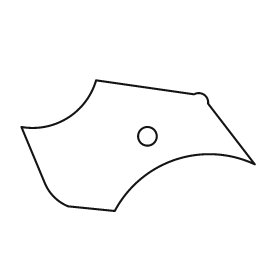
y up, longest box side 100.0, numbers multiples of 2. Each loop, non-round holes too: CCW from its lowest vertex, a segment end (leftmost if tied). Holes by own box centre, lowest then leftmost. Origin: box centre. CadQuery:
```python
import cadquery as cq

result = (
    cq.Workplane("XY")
    .moveTo(-10.0, -28.0)
    .threePointArc((16.0, -6.0), (50.0, -8.0))
    .lineTo(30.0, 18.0)
    .threePointArc((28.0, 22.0), (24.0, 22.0))
    .lineTo(-18.0, 28.0)
    .threePointArc((-30.0, 12.0), (-50.0, 8.0))
    .lineTo(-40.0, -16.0)
    .threePointArc((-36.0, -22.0), (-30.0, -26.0))
    .close()
    .moveTo(4.0, 4.0)
    .circle(4.0)
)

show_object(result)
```